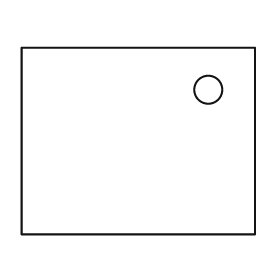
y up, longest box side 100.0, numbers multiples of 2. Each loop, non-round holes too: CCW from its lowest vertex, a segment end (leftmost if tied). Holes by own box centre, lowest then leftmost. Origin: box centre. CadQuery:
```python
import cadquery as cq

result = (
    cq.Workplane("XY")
    .moveTo(-50.0, -40.0)
    .lineTo(50.0, -40.0)
    .lineTo(50.0, 40.0)
    .lineTo(-50.0, 40.0)
    .close()
    .moveTo(30.0, 22.0)
    .circle(6.0)
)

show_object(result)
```